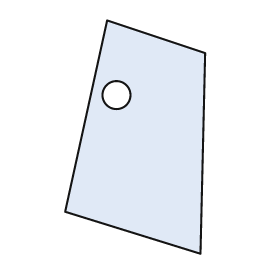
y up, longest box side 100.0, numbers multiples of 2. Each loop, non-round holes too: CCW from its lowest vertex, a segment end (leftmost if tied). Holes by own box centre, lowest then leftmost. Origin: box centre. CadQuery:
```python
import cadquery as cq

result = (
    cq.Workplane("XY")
    .moveTo(28.0, -50.0)
    .lineTo(30.0, 36.0)
    .lineTo(-12.0, 50.0)
    .lineTo(-30.0, -32.0)
    .close()
    .moveTo(-8.0, 18.0)
    .circle(6.0)
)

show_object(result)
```